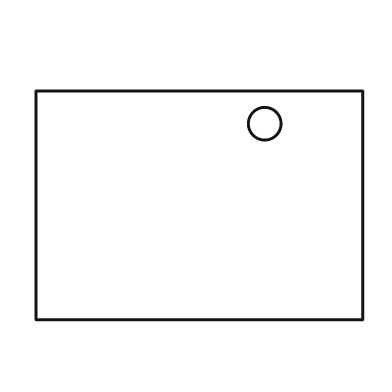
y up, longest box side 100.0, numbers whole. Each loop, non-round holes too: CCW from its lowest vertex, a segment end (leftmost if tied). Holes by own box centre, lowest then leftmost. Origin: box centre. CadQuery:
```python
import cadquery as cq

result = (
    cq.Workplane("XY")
    .moveTo(-50.0, -35.0)
    .lineTo(50.0, -35.0)
    .lineTo(50.0, 35.0)
    .lineTo(-50.0, 35.0)
    .close()
    .moveTo(20.0, 25.0)
    .circle(5.0)
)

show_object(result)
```